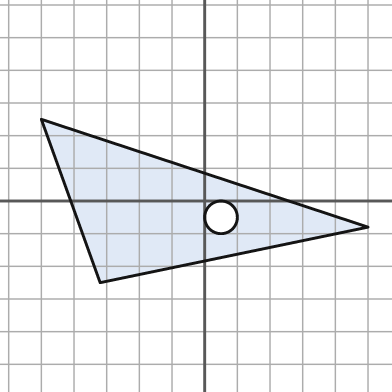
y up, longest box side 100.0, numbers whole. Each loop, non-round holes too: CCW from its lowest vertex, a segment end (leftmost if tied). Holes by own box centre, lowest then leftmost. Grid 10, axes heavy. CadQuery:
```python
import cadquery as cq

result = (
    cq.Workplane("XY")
    .moveTo(-32.0, -25.0)
    .lineTo(50.0, -8.0)
    .lineTo(-50.0, 25.0)
    .close()
    .moveTo(5.0, -5.0)
    .circle(5.0)
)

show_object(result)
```